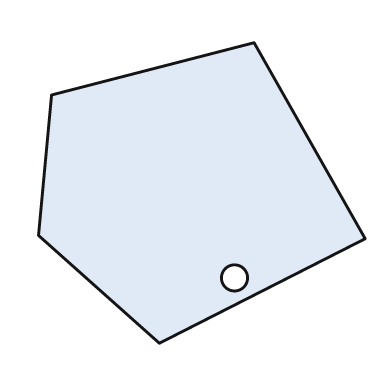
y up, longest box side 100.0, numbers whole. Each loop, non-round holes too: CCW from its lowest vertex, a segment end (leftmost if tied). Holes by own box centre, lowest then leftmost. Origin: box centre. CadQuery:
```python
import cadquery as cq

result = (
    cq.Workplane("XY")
    .moveTo(-13.0, -46.0)
    .lineTo(50.0, -14.0)
    .lineTo(16.0, 46.0)
    .lineTo(-46.0, 30.0)
    .lineTo(-50.0, -13.0)
    .close()
    .moveTo(10.0, -26.0)
    .circle(4.0)
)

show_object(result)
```